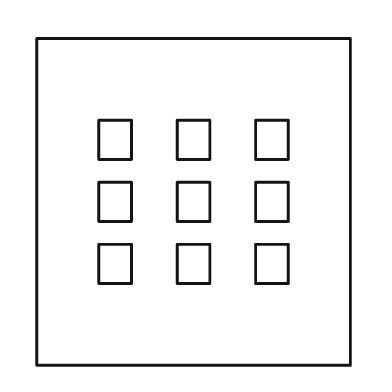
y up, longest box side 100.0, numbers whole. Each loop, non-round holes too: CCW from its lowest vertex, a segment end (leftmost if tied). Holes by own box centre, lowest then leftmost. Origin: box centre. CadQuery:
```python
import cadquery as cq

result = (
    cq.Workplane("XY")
    .moveTo(-48.0, -50.0)
    .lineTo(48.0, -50.0)
    .lineTo(48.0, 50.0)
    .lineTo(-48.0, 50.0)
    .close()
    .moveTo(-29.0, -25.0)
    .lineTo(-19.0, -25.0)
    .lineTo(-19.0, -13.0)
    .lineTo(-29.0, -13.0)
    .close()
    .moveTo(-5.0, -25.0)
    .lineTo(5.0, -25.0)
    .lineTo(5.0, -13.0)
    .lineTo(-5.0, -13.0)
    .close()
    .moveTo(19.0, -25.0)
    .lineTo(29.0, -25.0)
    .lineTo(29.0, -13.0)
    .lineTo(19.0, -13.0)
    .close()
    .moveTo(-29.0, -6.0)
    .lineTo(-19.0, -6.0)
    .lineTo(-19.0, 6.0)
    .lineTo(-29.0, 6.0)
    .close()
    .moveTo(-5.0, -6.0)
    .lineTo(5.0, -6.0)
    .lineTo(5.0, 6.0)
    .lineTo(-5.0, 6.0)
    .close()
    .moveTo(19.0, -6.0)
    .lineTo(29.0, -6.0)
    .lineTo(29.0, 6.0)
    .lineTo(19.0, 6.0)
    .close()
    .moveTo(-29.0, 13.0)
    .lineTo(-19.0, 13.0)
    .lineTo(-19.0, 25.0)
    .lineTo(-29.0, 25.0)
    .close()
    .moveTo(-5.0, 13.0)
    .lineTo(5.0, 13.0)
    .lineTo(5.0, 25.0)
    .lineTo(-5.0, 25.0)
    .close()
    .moveTo(19.0, 13.0)
    .lineTo(29.0, 13.0)
    .lineTo(29.0, 25.0)
    .lineTo(19.0, 25.0)
    .close()
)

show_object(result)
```